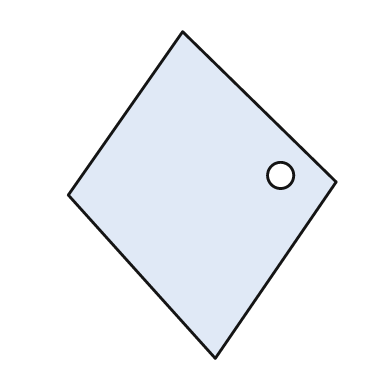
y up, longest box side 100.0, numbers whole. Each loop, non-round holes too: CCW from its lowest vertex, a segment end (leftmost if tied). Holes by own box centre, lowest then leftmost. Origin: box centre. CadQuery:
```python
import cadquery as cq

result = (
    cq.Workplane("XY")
    .moveTo(4.0, -50.0)
    .lineTo(41.0, 4.0)
    .lineTo(-6.0, 50.0)
    .lineTo(-41.0, 0.0)
    .close()
    .moveTo(24.0, 6.0)
    .circle(4.0)
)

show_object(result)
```